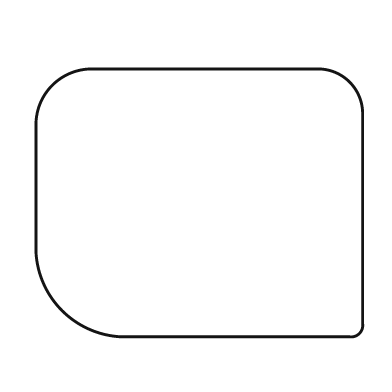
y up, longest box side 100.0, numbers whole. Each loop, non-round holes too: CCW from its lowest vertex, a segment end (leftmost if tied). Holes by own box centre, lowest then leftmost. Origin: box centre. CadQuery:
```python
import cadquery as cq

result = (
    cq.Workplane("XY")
    .moveTo(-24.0, -41.0)
    .lineTo(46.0, -41.0)
    .threePointArc((49.0, -40.0), (50.0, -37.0))
    .lineTo(50.0, 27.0)
    .threePointArc((46.0, 37.0), (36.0, 41.0))
    .lineTo(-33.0, 41.0)
    .threePointArc((-45.0, 36.0), (-50.0, 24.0))
    .lineTo(-50.0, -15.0)
    .threePointArc((-42.0, -33.0), (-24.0, -41.0))
    .close()
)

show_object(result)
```